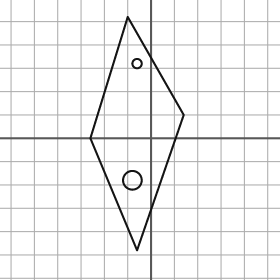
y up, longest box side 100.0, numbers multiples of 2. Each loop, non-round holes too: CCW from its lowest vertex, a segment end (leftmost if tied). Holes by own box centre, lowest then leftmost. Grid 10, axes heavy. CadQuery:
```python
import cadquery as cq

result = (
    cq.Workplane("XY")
    .moveTo(-6.0, -48.0)
    .lineTo(14.0, 10.0)
    .lineTo(-10.0, 52.0)
    .lineTo(-26.0, 0.0)
    .close()
    .moveTo(-8.0, -18.0)
    .circle(4.0)
    .moveTo(-6.0, 32.0)
    .circle(2.0)
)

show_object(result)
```